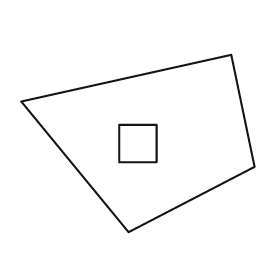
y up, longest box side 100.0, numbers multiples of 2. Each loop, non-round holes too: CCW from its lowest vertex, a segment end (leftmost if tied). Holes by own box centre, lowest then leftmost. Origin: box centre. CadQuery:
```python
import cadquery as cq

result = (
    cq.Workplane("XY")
    .moveTo(-4.0, -38.0)
    .lineTo(50.0, -10.0)
    .lineTo(40.0, 38.0)
    .lineTo(-50.0, 18.0)
    .close()
    .moveTo(-8.0, -8.0)
    .lineTo(8.0, -8.0)
    .lineTo(8.0, 8.0)
    .lineTo(-8.0, 8.0)
    .close()
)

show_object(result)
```